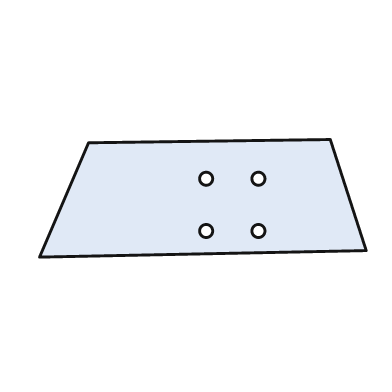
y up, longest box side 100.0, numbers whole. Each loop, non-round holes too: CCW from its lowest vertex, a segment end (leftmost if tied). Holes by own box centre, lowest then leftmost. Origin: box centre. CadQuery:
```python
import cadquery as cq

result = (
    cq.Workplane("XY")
    .moveTo(-50.0, -18.0)
    .lineTo(50.0, -16.0)
    .lineTo(39.0, 18.0)
    .lineTo(-35.0, 17.0)
    .close()
    .moveTo(1.0, -10.0)
    .circle(2.0)
    .moveTo(17.0, -10.0)
    .circle(2.0)
    .moveTo(1.0, 6.0)
    .circle(2.0)
    .moveTo(17.0, 6.0)
    .circle(2.0)
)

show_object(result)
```